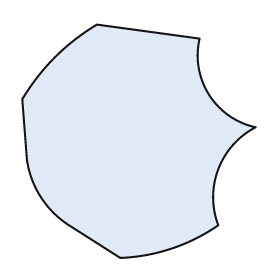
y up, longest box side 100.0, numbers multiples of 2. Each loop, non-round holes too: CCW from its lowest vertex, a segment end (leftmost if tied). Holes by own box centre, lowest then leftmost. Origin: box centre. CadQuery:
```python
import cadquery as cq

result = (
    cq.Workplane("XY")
    .moveTo(-8.0, -50.0)
    .threePointArc((14.0, -46.0), (34.0, -36.0))
    .threePointArc((34.0, -12.0), (50.0, 6.0))
    .threePointArc((30.0, 20.0), (26.0, 44.0))
    .lineTo(-18.0, 50.0)
    .threePointArc((-36.0, 36.0), (-50.0, 18.0))
    .lineTo(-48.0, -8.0)
    .threePointArc((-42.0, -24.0), (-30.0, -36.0))
    .close()
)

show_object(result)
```